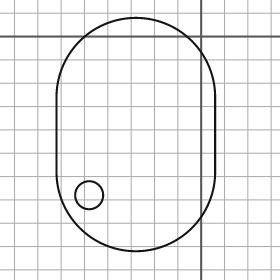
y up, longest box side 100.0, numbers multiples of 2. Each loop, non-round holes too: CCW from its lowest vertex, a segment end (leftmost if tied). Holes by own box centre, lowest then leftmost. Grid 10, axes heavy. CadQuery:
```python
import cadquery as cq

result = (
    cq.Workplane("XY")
    .moveTo(-62.0, -58.0)
    .threePointArc((-28.0, -92.0), (6.0, -58.0))
    .lineTo(6.0, -26.0)
    .threePointArc((-28.0, 8.0), (-62.0, -26.0))
    .close()
    .moveTo(-48.0, -68.0)
    .circle(6.0)
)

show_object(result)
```